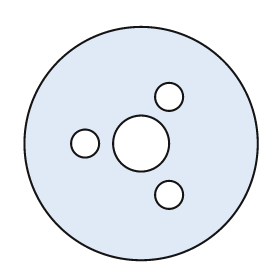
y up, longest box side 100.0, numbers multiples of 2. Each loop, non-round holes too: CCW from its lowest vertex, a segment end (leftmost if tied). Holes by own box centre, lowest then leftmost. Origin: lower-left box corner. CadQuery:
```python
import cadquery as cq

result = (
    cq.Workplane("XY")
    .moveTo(50.0, 50.0)
    .circle(50.0)
    .moveTo(62.0, 28.0)
    .circle(6.0)
    .moveTo(26.0, 50.0)
    .circle(6.0)
    .moveTo(50.0, 50.0)
    .circle(12.0)
    .moveTo(62.0, 70.0)
    .circle(6.0)
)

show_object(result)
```